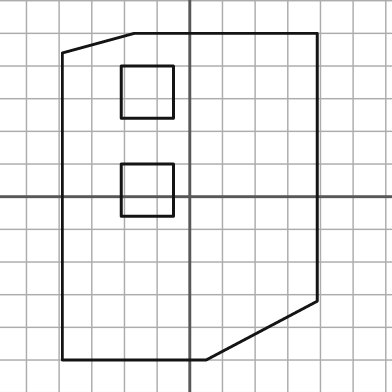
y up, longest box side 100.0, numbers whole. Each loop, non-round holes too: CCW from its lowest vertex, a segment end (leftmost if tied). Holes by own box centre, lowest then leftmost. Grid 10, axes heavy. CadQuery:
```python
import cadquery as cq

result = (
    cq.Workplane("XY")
    .moveTo(-39.0, -50.0)
    .lineTo(5.0, -50.0)
    .lineTo(39.0, -32.0)
    .lineTo(39.0, 50.0)
    .lineTo(-17.0, 50.0)
    .lineTo(-39.0, 44.0)
    .close()
    .moveTo(-21.0, -6.0)
    .lineTo(-5.0, -6.0)
    .lineTo(-5.0, 10.0)
    .lineTo(-21.0, 10.0)
    .close()
    .moveTo(-21.0, 24.0)
    .lineTo(-5.0, 24.0)
    .lineTo(-5.0, 40.0)
    .lineTo(-21.0, 40.0)
    .close()
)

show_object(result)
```